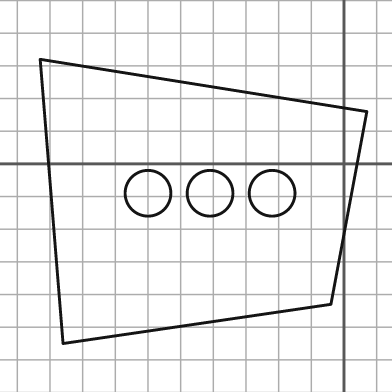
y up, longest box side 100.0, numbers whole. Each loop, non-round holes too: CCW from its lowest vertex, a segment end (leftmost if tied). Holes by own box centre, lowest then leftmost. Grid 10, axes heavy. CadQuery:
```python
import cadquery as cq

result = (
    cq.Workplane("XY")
    .moveTo(-86.0, -55.0)
    .lineTo(-4.0, -43.0)
    .lineTo(7.0, 16.0)
    .lineTo(-93.0, 32.0)
    .close()
    .moveTo(-60.0, -9.0)
    .circle(7.0)
    .moveTo(-41.0, -9.0)
    .circle(7.0)
    .moveTo(-22.0, -9.0)
    .circle(7.0)
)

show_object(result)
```